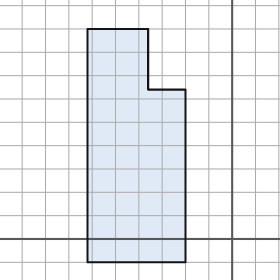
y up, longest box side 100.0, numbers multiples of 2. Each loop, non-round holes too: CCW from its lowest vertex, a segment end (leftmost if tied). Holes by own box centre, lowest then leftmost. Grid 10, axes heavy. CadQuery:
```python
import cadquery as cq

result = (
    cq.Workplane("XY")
    .moveTo(-62.0, -10.0)
    .lineTo(-20.0, -10.0)
    .lineTo(-20.0, 64.0)
    .lineTo(-36.0, 64.0)
    .lineTo(-36.0, 90.0)
    .lineTo(-62.0, 90.0)
    .close()
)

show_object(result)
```